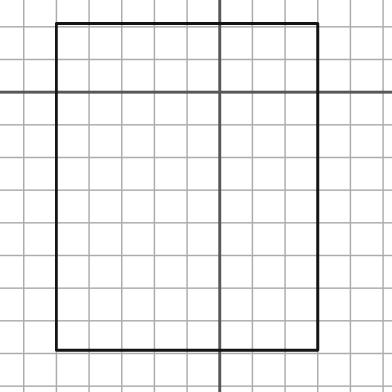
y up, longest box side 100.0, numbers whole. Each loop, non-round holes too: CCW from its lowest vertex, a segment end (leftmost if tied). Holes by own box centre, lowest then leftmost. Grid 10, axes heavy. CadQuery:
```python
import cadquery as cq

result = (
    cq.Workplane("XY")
    .moveTo(-50.0, -79.0)
    .lineTo(30.0, -79.0)
    .lineTo(30.0, 21.0)
    .lineTo(-50.0, 21.0)
    .close()
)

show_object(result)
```